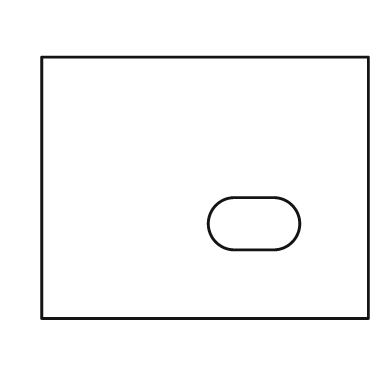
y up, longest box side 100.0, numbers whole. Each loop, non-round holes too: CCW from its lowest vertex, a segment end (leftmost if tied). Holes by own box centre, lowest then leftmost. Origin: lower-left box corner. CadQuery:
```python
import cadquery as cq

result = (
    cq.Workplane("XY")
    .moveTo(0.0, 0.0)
    .lineTo(100.0, 0.0)
    .lineTo(100.0, 80.0)
    .lineTo(0.0, 80.0)
    .close()
    .moveTo(59.0, 21.0)
    .lineTo(71.0, 21.0)
    .threePointArc((79.0, 29.0), (71.0, 37.0))
    .lineTo(59.0, 37.0)
    .threePointArc((51.0, 29.0), (59.0, 21.0))
    .close()
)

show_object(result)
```